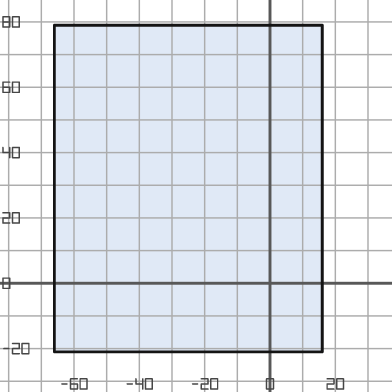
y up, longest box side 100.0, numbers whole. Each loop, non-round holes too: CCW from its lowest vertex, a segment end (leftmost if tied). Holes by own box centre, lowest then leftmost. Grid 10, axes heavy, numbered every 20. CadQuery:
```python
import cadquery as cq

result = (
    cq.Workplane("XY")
    .moveTo(-66.0, -21.0)
    .lineTo(16.0, -21.0)
    .lineTo(16.0, 79.0)
    .lineTo(-66.0, 79.0)
    .close()
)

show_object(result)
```